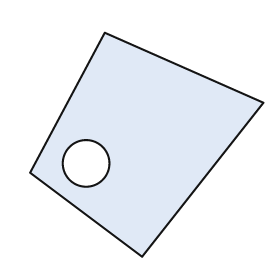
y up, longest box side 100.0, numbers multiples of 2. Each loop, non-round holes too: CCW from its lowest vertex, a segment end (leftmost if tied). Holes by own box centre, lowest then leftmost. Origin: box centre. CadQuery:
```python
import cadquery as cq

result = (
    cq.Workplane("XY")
    .moveTo(-2.0, -48.0)
    .lineTo(50.0, 18.0)
    .lineTo(-18.0, 48.0)
    .lineTo(-50.0, -12.0)
    .close()
    .moveTo(-26.0, -8.0)
    .circle(10.0)
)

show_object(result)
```